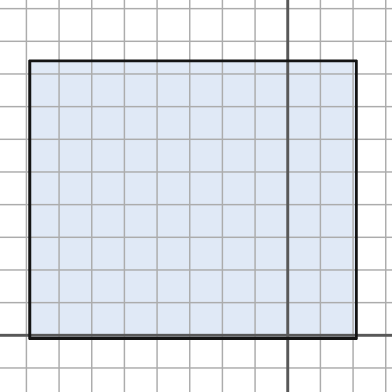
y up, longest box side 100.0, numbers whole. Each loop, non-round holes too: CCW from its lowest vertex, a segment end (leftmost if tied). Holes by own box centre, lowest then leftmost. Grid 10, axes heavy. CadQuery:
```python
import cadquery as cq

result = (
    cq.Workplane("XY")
    .moveTo(-79.0, -1.0)
    .lineTo(21.0, -1.0)
    .lineTo(21.0, 84.0)
    .lineTo(-79.0, 84.0)
    .close()
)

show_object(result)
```